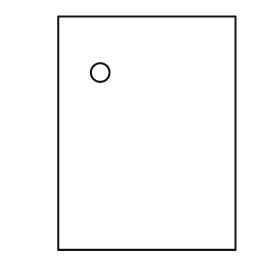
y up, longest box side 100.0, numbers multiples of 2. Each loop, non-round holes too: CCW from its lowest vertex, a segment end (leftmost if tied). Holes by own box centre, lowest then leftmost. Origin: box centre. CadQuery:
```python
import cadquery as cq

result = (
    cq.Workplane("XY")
    .moveTo(-38.0, -50.0)
    .lineTo(38.0, -50.0)
    .lineTo(38.0, 50.0)
    .lineTo(-38.0, 50.0)
    .close()
    .moveTo(-20.0, 26.0)
    .circle(4.0)
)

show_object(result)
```